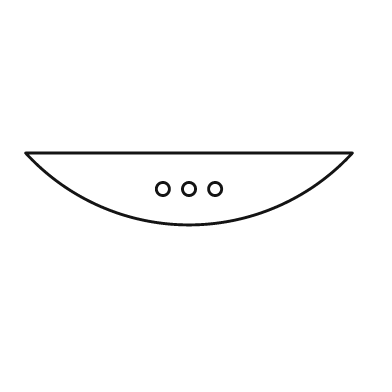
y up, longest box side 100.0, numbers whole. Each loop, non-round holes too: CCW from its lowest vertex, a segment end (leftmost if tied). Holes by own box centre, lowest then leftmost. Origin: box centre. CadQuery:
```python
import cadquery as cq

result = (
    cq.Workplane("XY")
    .moveTo(-50.0, 11.0)
    .threePointArc((0.0, -11.0), (50.0, 11.0))
    .close()
    .moveTo(-8.0, 0.0)
    .circle(2.0)
    .moveTo(0.0, 0.0)
    .circle(2.0)
    .moveTo(8.0, 0.0)
    .circle(2.0)
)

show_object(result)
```